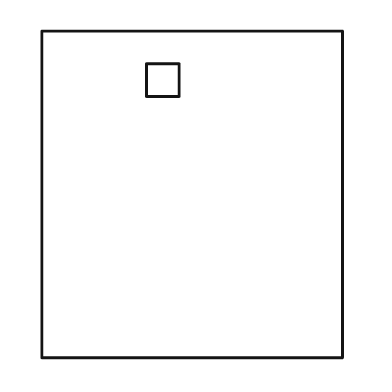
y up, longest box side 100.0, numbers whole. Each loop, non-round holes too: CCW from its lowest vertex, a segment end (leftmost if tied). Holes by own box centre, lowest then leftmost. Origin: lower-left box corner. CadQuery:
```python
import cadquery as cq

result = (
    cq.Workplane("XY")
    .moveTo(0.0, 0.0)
    .lineTo(92.0, 0.0)
    .lineTo(92.0, 100.0)
    .lineTo(0.0, 100.0)
    .close()
    .moveTo(32.0, 80.0)
    .lineTo(42.0, 80.0)
    .lineTo(42.0, 90.0)
    .lineTo(32.0, 90.0)
    .close()
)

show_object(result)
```